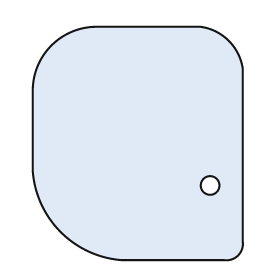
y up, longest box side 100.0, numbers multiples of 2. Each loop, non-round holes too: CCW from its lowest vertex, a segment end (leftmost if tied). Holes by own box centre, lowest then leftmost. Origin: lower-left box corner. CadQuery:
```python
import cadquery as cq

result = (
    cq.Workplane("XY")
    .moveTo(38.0, 0.0)
    .lineTo(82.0, 0.0)
    .threePointArc((88.0, 2.0), (90.0, 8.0))
    .lineTo(90.0, 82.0)
    .threePointArc((84.0, 94.0), (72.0, 100.0))
    .lineTo(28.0, 100.0)
    .threePointArc((8.0, 92.0), (0.0, 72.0))
    .lineTo(0.0, 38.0)
    .threePointArc((12.0, 12.0), (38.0, 0.0))
    .close()
    .moveTo(76.0, 32.0)
    .circle(4.0)
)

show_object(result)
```